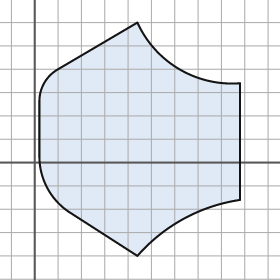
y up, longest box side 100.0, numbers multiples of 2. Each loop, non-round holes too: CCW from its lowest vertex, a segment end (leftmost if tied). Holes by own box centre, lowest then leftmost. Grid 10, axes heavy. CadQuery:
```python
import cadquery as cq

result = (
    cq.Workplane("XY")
    .moveTo(44.0, -40.0)
    .threePointArc((64.0, -24.0), (88.0, -16.0))
    .lineTo(88.0, 34.0)
    .threePointArc((62.0, 40.0), (44.0, 60.0))
    .lineTo(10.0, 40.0)
    .threePointArc((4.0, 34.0), (2.0, 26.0))
    .lineTo(2.0, 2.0)
    .threePointArc((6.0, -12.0), (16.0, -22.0))
    .close()
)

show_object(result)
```